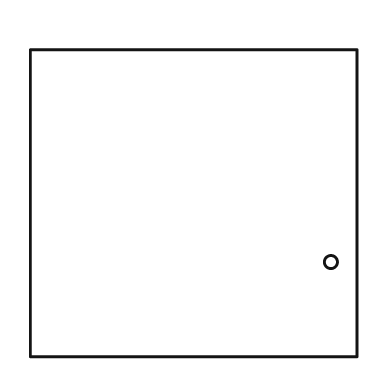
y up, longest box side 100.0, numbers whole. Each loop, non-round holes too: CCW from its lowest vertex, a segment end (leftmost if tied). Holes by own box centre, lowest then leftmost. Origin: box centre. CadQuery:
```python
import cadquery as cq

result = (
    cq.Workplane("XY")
    .moveTo(-50.0, -47.0)
    .lineTo(50.0, -47.0)
    .lineTo(50.0, 47.0)
    .lineTo(-50.0, 47.0)
    .close()
    .moveTo(42.0, -18.0)
    .circle(2.0)
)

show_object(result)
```